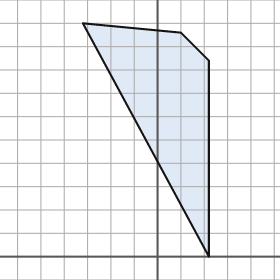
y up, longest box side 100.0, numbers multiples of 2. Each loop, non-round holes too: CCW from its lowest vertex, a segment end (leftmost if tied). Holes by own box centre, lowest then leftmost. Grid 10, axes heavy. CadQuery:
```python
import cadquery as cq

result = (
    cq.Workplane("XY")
    .moveTo(22.0, 0.0)
    .lineTo(22.0, 84.0)
    .lineTo(10.0, 96.0)
    .lineTo(-32.0, 100.0)
    .close()
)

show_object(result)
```